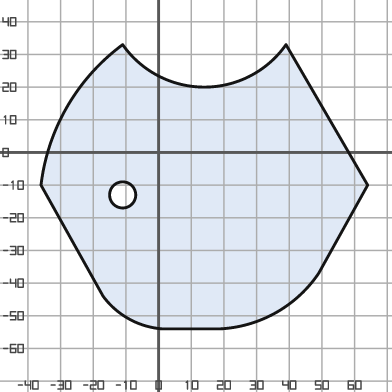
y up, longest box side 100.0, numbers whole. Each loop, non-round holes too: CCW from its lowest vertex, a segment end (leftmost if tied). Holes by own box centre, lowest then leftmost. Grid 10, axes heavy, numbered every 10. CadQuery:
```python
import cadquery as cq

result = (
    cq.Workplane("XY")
    .moveTo(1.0, -54.0)
    .lineTo(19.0, -54.0)
    .threePointArc((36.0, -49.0), (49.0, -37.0))
    .lineTo(64.0, -10.0)
    .lineTo(39.0, 33.0)
    .threePointArc((14.0, 20.0), (-11.0, 33.0))
    .threePointArc((-28.0, 14.0), (-36.0, -10.0))
    .lineTo(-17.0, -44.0)
    .threePointArc((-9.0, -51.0), (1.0, -54.0))
    .close()
    .moveTo(-11.0, -13.0)
    .circle(4.0)
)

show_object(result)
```